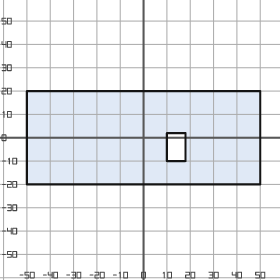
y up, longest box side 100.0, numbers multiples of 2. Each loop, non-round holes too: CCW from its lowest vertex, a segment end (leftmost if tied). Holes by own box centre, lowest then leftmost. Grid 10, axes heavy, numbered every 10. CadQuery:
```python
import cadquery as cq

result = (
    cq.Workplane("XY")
    .moveTo(-50.0, -20.0)
    .lineTo(50.0, -20.0)
    .lineTo(50.0, 20.0)
    .lineTo(-50.0, 20.0)
    .close()
    .moveTo(10.0, -10.0)
    .lineTo(18.0, -10.0)
    .lineTo(18.0, 2.0)
    .lineTo(10.0, 2.0)
    .close()
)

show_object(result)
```